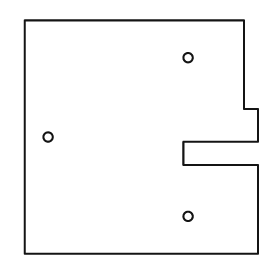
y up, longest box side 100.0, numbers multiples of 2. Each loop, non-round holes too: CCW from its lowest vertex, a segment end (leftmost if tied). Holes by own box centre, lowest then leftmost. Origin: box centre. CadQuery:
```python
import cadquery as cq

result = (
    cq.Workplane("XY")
    .moveTo(-50.0, -50.0)
    .lineTo(50.0, -50.0)
    .lineTo(50.0, -12.0)
    .lineTo(18.0, -12.0)
    .lineTo(18.0, -2.0)
    .lineTo(50.0, -2.0)
    .lineTo(50.0, 12.0)
    .lineTo(44.0, 12.0)
    .lineTo(44.0, 50.0)
    .lineTo(-50.0, 50.0)
    .close()
    .moveTo(20.0, -34.0)
    .circle(2.0)
    .moveTo(-40.0, 0.0)
    .circle(2.0)
    .moveTo(20.0, 34.0)
    .circle(2.0)
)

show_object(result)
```